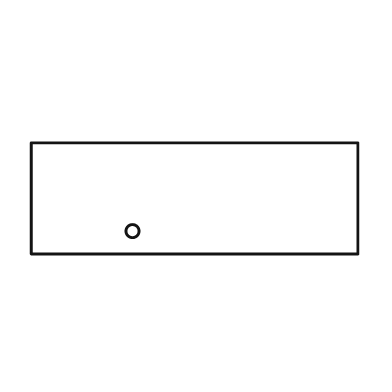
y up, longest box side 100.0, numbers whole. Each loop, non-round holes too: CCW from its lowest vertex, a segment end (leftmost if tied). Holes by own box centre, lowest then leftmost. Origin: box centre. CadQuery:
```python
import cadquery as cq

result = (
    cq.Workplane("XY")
    .moveTo(-50.0, -17.0)
    .lineTo(50.0, -17.0)
    .lineTo(50.0, 17.0)
    .lineTo(-50.0, 17.0)
    .close()
    .moveTo(-19.0, -10.0)
    .circle(2.0)
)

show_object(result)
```